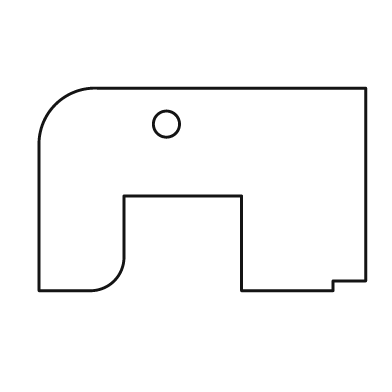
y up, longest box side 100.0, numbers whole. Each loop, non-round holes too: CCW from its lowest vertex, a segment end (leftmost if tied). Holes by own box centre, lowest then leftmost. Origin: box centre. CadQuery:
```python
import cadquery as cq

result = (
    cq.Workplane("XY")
    .moveTo(-50.0, -31.0)
    .lineTo(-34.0, -31.0)
    .threePointArc((-27.0, -28.0), (-24.0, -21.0))
    .lineTo(-24.0, -2.0)
    .lineTo(12.0, -2.0)
    .lineTo(12.0, -31.0)
    .lineTo(40.0, -31.0)
    .lineTo(40.0, -28.0)
    .lineTo(50.0, -28.0)
    .lineTo(50.0, 31.0)
    .lineTo(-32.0, 31.0)
    .threePointArc((-45.0, 26.0), (-50.0, 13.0))
    .close()
    .moveTo(-11.0, 20.0)
    .circle(4.0)
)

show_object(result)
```